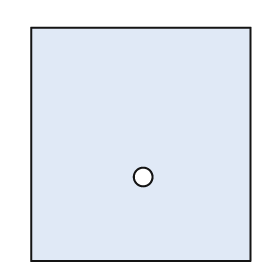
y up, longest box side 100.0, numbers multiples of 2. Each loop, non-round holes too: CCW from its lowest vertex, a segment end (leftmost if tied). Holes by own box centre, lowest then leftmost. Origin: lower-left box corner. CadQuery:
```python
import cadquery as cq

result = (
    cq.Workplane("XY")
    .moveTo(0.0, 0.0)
    .lineTo(94.0, 0.0)
    .lineTo(94.0, 100.0)
    .lineTo(0.0, 100.0)
    .close()
    .moveTo(48.0, 36.0)
    .circle(4.0)
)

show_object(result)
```